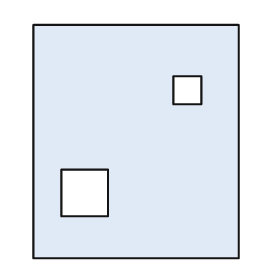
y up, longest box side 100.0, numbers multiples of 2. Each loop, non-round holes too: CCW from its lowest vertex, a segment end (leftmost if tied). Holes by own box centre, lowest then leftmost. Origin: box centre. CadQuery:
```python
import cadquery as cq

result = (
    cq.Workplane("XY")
    .moveTo(-44.0, -50.0)
    .lineTo(44.0, -50.0)
    .lineTo(44.0, 50.0)
    .lineTo(-44.0, 50.0)
    .close()
    .moveTo(-32.0, -32.0)
    .lineTo(-12.0, -32.0)
    .lineTo(-12.0, -12.0)
    .lineTo(-32.0, -12.0)
    .close()
    .moveTo(16.0, 16.0)
    .lineTo(28.0, 16.0)
    .lineTo(28.0, 28.0)
    .lineTo(16.0, 28.0)
    .close()
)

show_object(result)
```